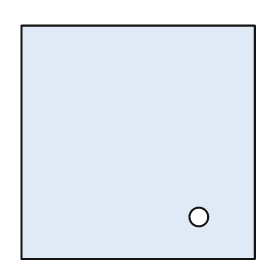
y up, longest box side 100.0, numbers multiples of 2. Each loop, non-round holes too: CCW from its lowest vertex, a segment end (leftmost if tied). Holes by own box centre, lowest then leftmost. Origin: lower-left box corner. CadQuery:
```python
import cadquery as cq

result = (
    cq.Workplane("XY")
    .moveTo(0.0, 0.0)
    .lineTo(100.0, 0.0)
    .lineTo(100.0, 100.0)
    .lineTo(0.0, 100.0)
    .close()
    .moveTo(76.0, 18.0)
    .circle(4.0)
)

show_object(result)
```